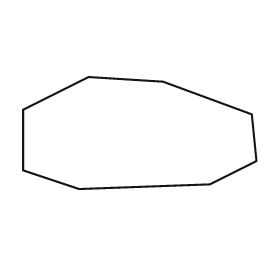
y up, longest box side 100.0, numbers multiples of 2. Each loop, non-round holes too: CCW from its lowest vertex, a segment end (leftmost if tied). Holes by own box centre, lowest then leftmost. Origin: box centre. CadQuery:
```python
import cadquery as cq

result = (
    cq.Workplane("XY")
    .moveTo(-26.0, -24.0)
    .lineTo(30.0, -22.0)
    .lineTo(50.0, -12.0)
    .lineTo(48.0, 8.0)
    .lineTo(10.0, 22.0)
    .lineTo(-22.0, 24.0)
    .lineTo(-50.0, 10.0)
    .lineTo(-50.0, -16.0)
    .close()
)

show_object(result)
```